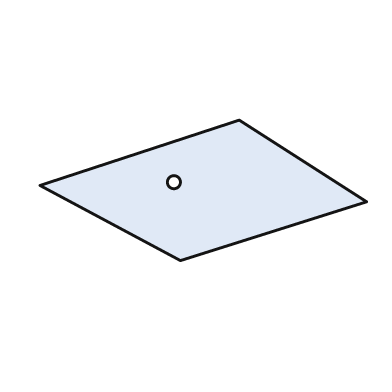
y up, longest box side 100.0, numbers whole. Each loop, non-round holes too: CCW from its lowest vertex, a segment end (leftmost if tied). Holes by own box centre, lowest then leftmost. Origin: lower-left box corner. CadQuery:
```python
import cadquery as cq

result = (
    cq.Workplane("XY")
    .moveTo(43.0, 0.0)
    .lineTo(100.0, 18.0)
    .lineTo(61.0, 43.0)
    .lineTo(0.0, 23.0)
    .close()
    .moveTo(41.0, 24.0)
    .circle(2.0)
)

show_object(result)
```